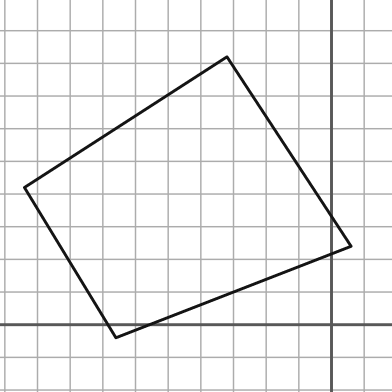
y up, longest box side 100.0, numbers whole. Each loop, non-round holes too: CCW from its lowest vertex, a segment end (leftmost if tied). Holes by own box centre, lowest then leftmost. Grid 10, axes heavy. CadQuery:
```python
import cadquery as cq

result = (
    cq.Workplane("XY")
    .moveTo(-66.0, -4.0)
    .lineTo(6.0, 24.0)
    .lineTo(-32.0, 82.0)
    .lineTo(-94.0, 42.0)
    .close()
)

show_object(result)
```